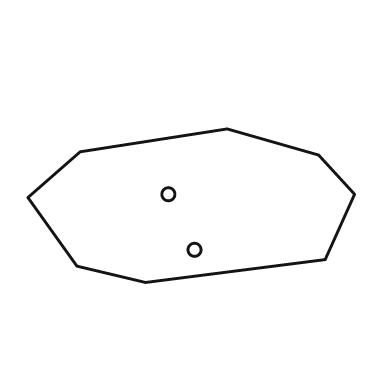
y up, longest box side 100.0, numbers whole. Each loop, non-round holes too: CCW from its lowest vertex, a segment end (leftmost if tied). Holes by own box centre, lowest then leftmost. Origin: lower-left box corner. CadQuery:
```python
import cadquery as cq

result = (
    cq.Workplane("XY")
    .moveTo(36.0, 0.0)
    .lineTo(91.0, 7.0)
    .lineTo(100.0, 27.0)
    .lineTo(89.0, 39.0)
    .lineTo(61.0, 47.0)
    .lineTo(16.0, 40.0)
    .lineTo(0.0, 26.0)
    .lineTo(15.0, 5.0)
    .close()
    .moveTo(51.0, 10.0)
    .circle(2.0)
    .moveTo(43.0, 27.0)
    .circle(2.0)
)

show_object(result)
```